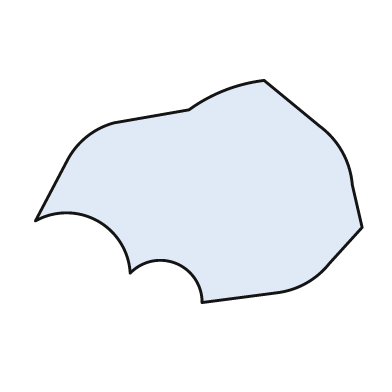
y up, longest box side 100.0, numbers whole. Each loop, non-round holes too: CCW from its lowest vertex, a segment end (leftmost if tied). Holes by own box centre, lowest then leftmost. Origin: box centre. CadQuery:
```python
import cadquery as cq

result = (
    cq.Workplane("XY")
    .moveTo(1.0, -34.0)
    .lineTo(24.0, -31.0)
    .threePointArc((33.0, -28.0), (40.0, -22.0))
    .lineTo(50.0, -11.0)
    .lineTo(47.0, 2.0)
    .threePointArc((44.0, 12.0), (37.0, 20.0))
    .lineTo(20.0, 34.0)
    .threePointArc((8.0, 31.0), (-3.0, 25.0))
    .lineTo(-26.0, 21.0)
    .threePointArc((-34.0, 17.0), (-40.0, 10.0))
    .lineTo(-50.0, -9.0)
    .threePointArc((-31.0, -9.0), (-21.0, -25.0))
    .threePointArc((-7.0, -22.0), (1.0, -34.0))
    .close()
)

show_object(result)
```